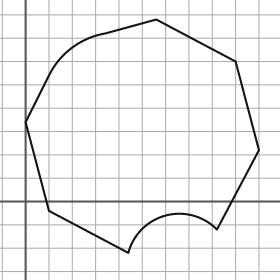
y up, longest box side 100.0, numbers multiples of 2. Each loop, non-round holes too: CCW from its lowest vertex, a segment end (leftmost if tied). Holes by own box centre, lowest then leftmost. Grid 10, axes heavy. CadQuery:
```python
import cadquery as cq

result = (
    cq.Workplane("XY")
    .moveTo(44.0, -22.0)
    .threePointArc((60.0, -6.0), (82.0, -12.0))
    .lineTo(100.0, 22.0)
    .lineTo(90.0, 60.0)
    .lineTo(56.0, 78.0)
    .lineTo(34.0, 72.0)
    .threePointArc((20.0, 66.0), (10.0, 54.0))
    .lineTo(0.0, 34.0)
    .lineTo(10.0, -4.0)
    .close()
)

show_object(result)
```